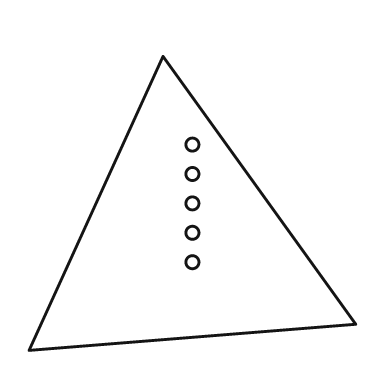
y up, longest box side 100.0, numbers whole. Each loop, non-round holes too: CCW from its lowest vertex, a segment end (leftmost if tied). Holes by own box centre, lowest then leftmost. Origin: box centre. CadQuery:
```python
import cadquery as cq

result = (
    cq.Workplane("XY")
    .moveTo(-50.0, -45.0)
    .lineTo(50.0, -37.0)
    .lineTo(-9.0, 45.0)
    .close()
    .moveTo(0.0, -18.0)
    .circle(2.0)
    .moveTo(0.0, -9.0)
    .circle(2.0)
    .moveTo(0.0, 0.0)
    .circle(2.0)
    .moveTo(0.0, 9.0)
    .circle(2.0)
    .moveTo(0.0, 18.0)
    .circle(2.0)
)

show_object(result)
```